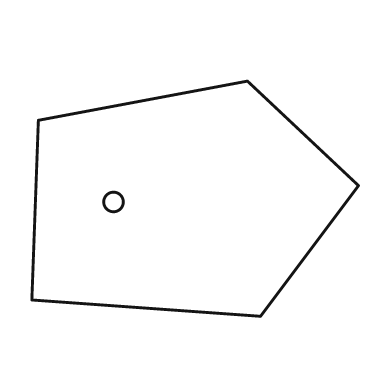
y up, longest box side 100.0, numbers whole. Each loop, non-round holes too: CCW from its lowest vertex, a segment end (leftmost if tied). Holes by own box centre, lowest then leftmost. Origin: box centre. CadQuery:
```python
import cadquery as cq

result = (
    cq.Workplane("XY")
    .moveTo(20.0, -36.0)
    .lineTo(50.0, 4.0)
    .lineTo(16.0, 36.0)
    .lineTo(-48.0, 24.0)
    .lineTo(-50.0, -31.0)
    .close()
    .moveTo(-25.0, -1.0)
    .circle(3.0)
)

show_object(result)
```